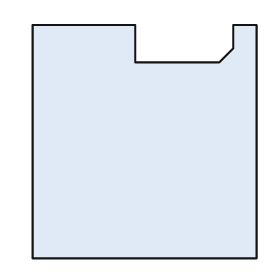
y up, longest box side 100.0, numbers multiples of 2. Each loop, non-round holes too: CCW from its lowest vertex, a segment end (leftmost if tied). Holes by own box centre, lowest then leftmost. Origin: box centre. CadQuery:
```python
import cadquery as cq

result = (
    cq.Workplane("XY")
    .moveTo(-48.0, -50.0)
    .lineTo(48.0, -50.0)
    .lineTo(48.0, 50.0)
    .lineTo(38.0, 50.0)
    .lineTo(38.0, 40.0)
    .lineTo(32.0, 34.0)
    .lineTo(-4.0, 34.0)
    .lineTo(-4.0, 50.0)
    .lineTo(-48.0, 50.0)
    .close()
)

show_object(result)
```